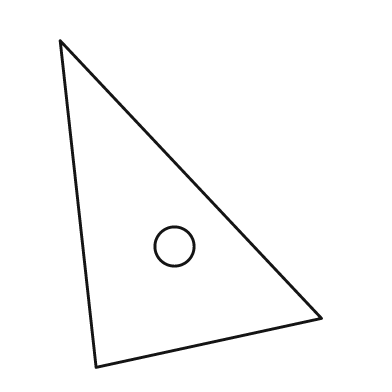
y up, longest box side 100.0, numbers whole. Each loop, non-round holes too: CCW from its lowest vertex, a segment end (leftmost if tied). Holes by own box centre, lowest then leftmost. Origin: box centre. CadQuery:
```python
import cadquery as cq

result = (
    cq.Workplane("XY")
    .moveTo(-29.0, -50.0)
    .lineTo(40.0, -35.0)
    .lineTo(-40.0, 50.0)
    .close()
    .moveTo(-5.0, -13.0)
    .circle(6.0)
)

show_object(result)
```